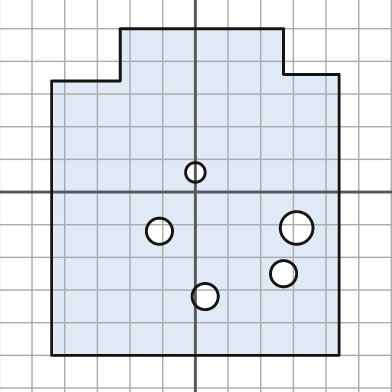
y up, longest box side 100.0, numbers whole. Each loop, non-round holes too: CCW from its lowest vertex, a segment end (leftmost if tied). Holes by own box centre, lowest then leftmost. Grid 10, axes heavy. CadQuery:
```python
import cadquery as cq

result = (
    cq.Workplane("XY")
    .moveTo(-44.0, -50.0)
    .lineTo(44.0, -50.0)
    .lineTo(44.0, 36.0)
    .lineTo(27.0, 36.0)
    .lineTo(27.0, 50.0)
    .lineTo(-23.0, 50.0)
    .lineTo(-23.0, 34.0)
    .lineTo(-44.0, 34.0)
    .close()
    .moveTo(3.0, -32.0)
    .circle(4.0)
    .moveTo(27.0, -25.0)
    .circle(4.0)
    .moveTo(-11.0, -12.0)
    .circle(4.0)
    .moveTo(31.0, -11.0)
    .circle(5.0)
    .moveTo(0.0, 6.0)
    .circle(3.0)
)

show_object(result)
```